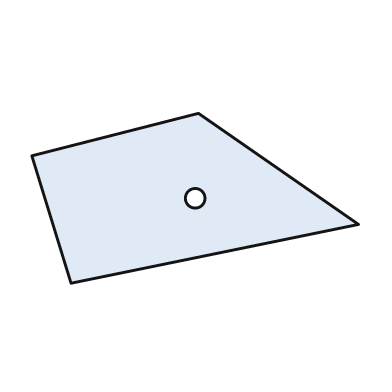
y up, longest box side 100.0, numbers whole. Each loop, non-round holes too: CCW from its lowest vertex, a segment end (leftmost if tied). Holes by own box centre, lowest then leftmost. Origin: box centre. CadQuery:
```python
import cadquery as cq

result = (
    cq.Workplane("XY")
    .moveTo(-38.0, -26.0)
    .lineTo(50.0, -8.0)
    .lineTo(1.0, 26.0)
    .lineTo(-50.0, 13.0)
    .close()
    .moveTo(0.0, 0.0)
    .circle(3.0)
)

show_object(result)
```